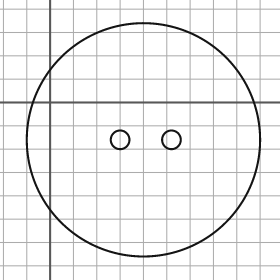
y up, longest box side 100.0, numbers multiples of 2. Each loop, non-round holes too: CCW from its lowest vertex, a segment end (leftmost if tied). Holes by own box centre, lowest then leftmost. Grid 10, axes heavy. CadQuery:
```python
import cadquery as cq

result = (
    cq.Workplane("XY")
    .moveTo(40.0, -16.0)
    .circle(50.0)
    .moveTo(30.0, -16.0)
    .circle(4.0)
    .moveTo(52.0, -16.0)
    .circle(4.0)
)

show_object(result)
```